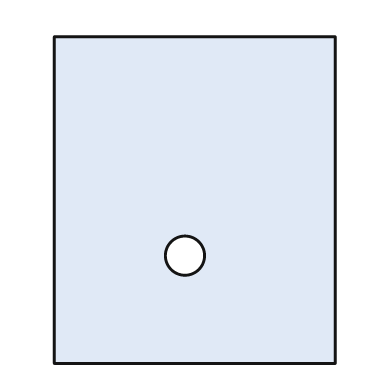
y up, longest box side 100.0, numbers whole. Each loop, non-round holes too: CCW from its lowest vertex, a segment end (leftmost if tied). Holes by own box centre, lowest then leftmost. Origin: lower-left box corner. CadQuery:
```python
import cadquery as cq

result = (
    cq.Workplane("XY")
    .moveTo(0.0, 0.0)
    .lineTo(86.0, 0.0)
    .lineTo(86.0, 100.0)
    .lineTo(0.0, 100.0)
    .close()
    .moveTo(40.0, 33.0)
    .circle(6.0)
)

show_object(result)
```